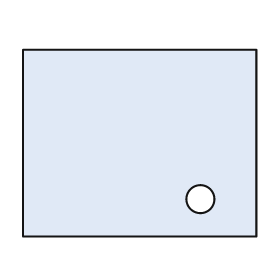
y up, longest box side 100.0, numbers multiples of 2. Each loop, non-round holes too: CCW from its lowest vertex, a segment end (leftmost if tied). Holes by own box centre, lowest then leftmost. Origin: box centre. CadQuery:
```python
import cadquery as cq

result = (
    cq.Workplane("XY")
    .moveTo(-50.0, -40.0)
    .lineTo(50.0, -40.0)
    .lineTo(50.0, 40.0)
    .lineTo(-50.0, 40.0)
    .close()
    .moveTo(26.0, -24.0)
    .circle(6.0)
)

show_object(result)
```